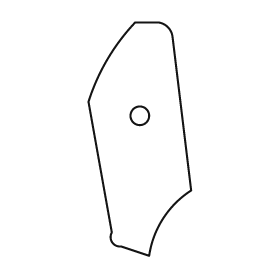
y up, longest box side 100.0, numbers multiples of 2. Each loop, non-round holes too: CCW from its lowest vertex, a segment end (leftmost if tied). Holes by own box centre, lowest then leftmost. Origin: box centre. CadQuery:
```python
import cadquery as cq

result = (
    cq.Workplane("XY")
    .moveTo(4.0, -50.0)
    .threePointArc((10.0, -34.0), (22.0, -22.0))
    .lineTo(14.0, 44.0)
    .threePointArc((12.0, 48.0), (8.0, 50.0))
    .lineTo(-2.0, 50.0)
    .threePointArc((-14.0, 34.0), (-22.0, 16.0))
    .lineTo(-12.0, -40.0)
    .threePointArc((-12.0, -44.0), (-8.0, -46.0))
    .close()
    .moveTo(0.0, 10.0)
    .circle(4.0)
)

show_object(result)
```